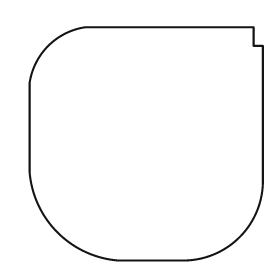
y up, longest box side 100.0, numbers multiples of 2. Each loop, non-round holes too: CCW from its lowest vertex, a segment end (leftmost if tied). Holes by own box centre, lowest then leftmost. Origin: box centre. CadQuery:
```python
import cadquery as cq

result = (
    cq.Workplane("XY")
    .moveTo(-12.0, -50.0)
    .lineTo(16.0, -50.0)
    .threePointArc((40.0, -40.0), (50.0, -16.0))
    .lineTo(50.0, 42.0)
    .lineTo(46.0, 42.0)
    .lineTo(46.0, 50.0)
    .lineTo(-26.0, 50.0)
    .threePointArc((-42.0, 42.0), (-50.0, 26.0))
    .lineTo(-50.0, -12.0)
    .threePointArc((-38.0, -38.0), (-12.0, -50.0))
    .close()
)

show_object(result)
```